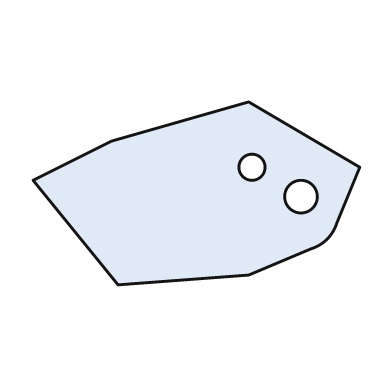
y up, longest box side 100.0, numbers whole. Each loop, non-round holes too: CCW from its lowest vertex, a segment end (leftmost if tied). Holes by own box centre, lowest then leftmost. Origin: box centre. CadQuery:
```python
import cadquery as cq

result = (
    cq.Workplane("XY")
    .moveTo(-24.0, -28.0)
    .lineTo(16.0, -25.0)
    .lineTo(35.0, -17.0)
    .threePointArc((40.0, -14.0), (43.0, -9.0))
    .lineTo(50.0, 8.0)
    .lineTo(16.0, 28.0)
    .lineTo(-26.0, 16.0)
    .lineTo(-50.0, 4.0)
    .close()
    .moveTo(32.0, -1.0)
    .circle(5.0)
    .moveTo(17.0, 8.0)
    .circle(4.0)
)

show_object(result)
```